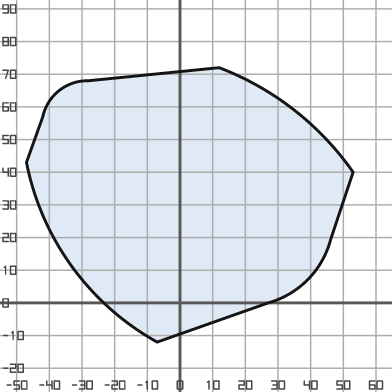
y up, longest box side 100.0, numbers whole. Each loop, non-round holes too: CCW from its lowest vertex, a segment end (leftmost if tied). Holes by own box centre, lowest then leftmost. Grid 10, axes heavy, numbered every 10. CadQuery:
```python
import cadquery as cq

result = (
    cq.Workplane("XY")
    .moveTo(-7.0, -12.0)
    .lineTo(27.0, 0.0)
    .threePointArc((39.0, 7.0), (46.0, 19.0))
    .lineTo(53.0, 40.0)
    .threePointArc((35.0, 59.0), (12.0, 72.0))
    .lineTo(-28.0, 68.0)
    .threePointArc((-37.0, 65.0), (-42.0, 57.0))
    .lineTo(-47.0, 43.0)
    .threePointArc((-33.0, 11.0), (-7.0, -12.0))
    .close()
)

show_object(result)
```